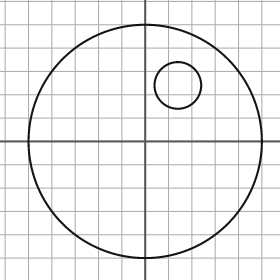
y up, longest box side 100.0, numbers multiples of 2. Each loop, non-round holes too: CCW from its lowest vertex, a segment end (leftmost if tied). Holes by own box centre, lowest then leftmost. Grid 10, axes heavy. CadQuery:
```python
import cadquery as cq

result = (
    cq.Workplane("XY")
    .moveTo(0.0, 0.0)
    .circle(50.0)
    .moveTo(14.0, 24.0)
    .circle(10.0)
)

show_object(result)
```